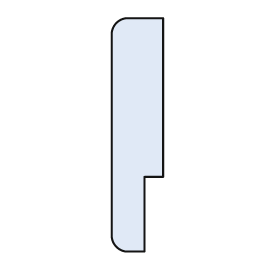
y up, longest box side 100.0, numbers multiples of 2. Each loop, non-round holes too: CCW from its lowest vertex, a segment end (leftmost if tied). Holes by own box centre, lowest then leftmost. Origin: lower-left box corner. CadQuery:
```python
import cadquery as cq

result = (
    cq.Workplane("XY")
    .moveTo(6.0, 0.0)
    .lineTo(14.0, 0.0)
    .lineTo(14.0, 32.0)
    .lineTo(22.0, 32.0)
    .lineTo(22.0, 100.0)
    .lineTo(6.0, 100.0)
    .threePointArc((2.0, 98.0), (0.0, 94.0))
    .lineTo(0.0, 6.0)
    .threePointArc((2.0, 2.0), (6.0, 0.0))
    .close()
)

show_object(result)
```